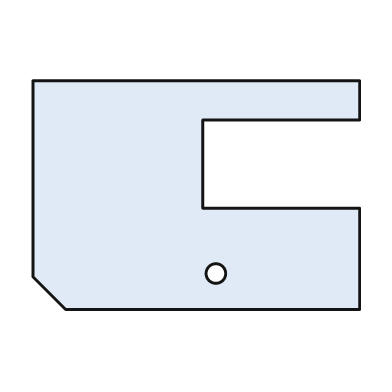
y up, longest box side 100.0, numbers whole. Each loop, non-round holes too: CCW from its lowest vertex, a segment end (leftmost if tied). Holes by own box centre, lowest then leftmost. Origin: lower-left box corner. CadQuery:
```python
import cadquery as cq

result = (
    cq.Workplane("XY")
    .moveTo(10.0, 0.0)
    .lineTo(100.0, 0.0)
    .lineTo(100.0, 31.0)
    .lineTo(52.0, 31.0)
    .lineTo(52.0, 58.0)
    .lineTo(100.0, 58.0)
    .lineTo(100.0, 70.0)
    .lineTo(0.0, 70.0)
    .lineTo(0.0, 10.0)
    .close()
    .moveTo(56.0, 11.0)
    .circle(3.0)
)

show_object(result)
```